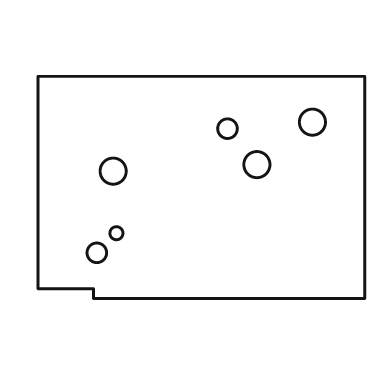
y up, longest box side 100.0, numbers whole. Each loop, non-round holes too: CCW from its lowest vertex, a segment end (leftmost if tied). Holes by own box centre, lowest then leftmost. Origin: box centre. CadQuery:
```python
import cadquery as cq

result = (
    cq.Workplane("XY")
    .moveTo(-33.0, -34.0)
    .lineTo(50.0, -34.0)
    .lineTo(50.0, 34.0)
    .lineTo(-50.0, 34.0)
    .lineTo(-50.0, -31.0)
    .lineTo(-33.0, -31.0)
    .close()
    .moveTo(-32.0, -20.0)
    .circle(3.0)
    .moveTo(-26.0, -14.0)
    .circle(2.0)
    .moveTo(-27.0, 5.0)
    .circle(4.0)
    .moveTo(17.0, 7.0)
    .circle(4.0)
    .moveTo(8.0, 18.0)
    .circle(3.0)
    .moveTo(34.0, 20.0)
    .circle(4.0)
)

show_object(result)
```